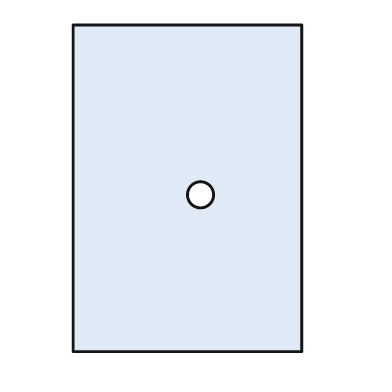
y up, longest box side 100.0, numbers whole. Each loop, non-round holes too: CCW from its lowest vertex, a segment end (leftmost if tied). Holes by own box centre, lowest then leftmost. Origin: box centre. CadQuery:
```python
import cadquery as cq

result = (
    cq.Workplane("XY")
    .moveTo(-35.0, -50.0)
    .lineTo(35.0, -50.0)
    .lineTo(35.0, 50.0)
    .lineTo(-35.0, 50.0)
    .close()
    .moveTo(4.0, -2.0)
    .circle(4.0)
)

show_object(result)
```